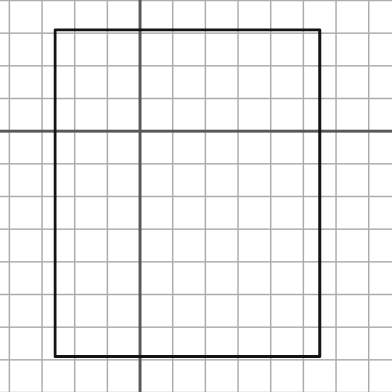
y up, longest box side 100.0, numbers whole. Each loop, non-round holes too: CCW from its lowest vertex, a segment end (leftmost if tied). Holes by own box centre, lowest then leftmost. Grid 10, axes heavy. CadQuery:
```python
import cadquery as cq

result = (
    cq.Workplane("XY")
    .moveTo(-26.0, -69.0)
    .lineTo(55.0, -69.0)
    .lineTo(55.0, 31.0)
    .lineTo(-26.0, 31.0)
    .close()
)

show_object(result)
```